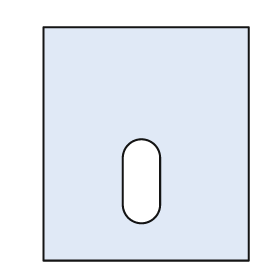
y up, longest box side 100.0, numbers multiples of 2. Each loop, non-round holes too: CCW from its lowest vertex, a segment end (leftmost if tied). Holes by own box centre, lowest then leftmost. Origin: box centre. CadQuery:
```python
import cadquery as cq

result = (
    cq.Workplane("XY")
    .moveTo(-44.0, -50.0)
    .lineTo(44.0, -50.0)
    .lineTo(44.0, 50.0)
    .lineTo(-44.0, 50.0)
    .close()
    .moveTo(-10.0, -26.0)
    .threePointArc((-2.0, -34.0), (6.0, -26.0))
    .lineTo(6.0, -6.0)
    .threePointArc((-2.0, 2.0), (-10.0, -6.0))
    .close()
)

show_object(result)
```